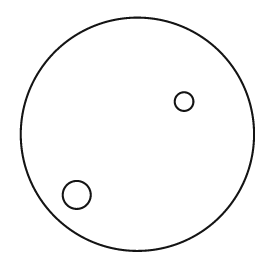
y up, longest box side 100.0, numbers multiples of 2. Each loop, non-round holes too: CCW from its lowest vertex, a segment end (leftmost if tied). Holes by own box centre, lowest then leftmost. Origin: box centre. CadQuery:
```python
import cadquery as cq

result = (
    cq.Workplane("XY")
    .moveTo(0.0, 0.0)
    .circle(50.0)
    .moveTo(-26.0, -26.0)
    .circle(6.0)
    .moveTo(20.0, 14.0)
    .circle(4.0)
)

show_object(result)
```